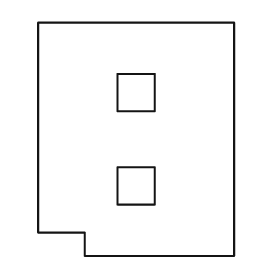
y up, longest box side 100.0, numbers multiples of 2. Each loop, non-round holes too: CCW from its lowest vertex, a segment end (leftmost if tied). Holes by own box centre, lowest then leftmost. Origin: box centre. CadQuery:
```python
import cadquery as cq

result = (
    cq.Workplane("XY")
    .moveTo(-22.0, -50.0)
    .lineTo(42.0, -50.0)
    .lineTo(42.0, 50.0)
    .lineTo(-42.0, 50.0)
    .lineTo(-42.0, -40.0)
    .lineTo(-22.0, -40.0)
    .close()
    .moveTo(-8.0, -28.0)
    .lineTo(8.0, -28.0)
    .lineTo(8.0, -12.0)
    .lineTo(-8.0, -12.0)
    .close()
    .moveTo(-8.0, 12.0)
    .lineTo(8.0, 12.0)
    .lineTo(8.0, 28.0)
    .lineTo(-8.0, 28.0)
    .close()
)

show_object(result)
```